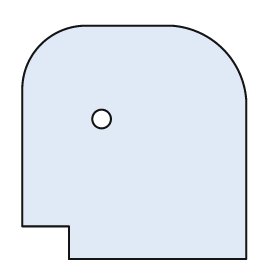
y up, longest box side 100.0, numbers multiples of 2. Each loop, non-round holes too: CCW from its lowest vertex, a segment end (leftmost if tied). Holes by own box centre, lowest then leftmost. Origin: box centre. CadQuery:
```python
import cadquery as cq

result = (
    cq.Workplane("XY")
    .moveTo(-28.0, -50.0)
    .lineTo(48.0, -50.0)
    .lineTo(48.0, 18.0)
    .threePointArc((38.0, 40.0), (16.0, 50.0))
    .lineTo(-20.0, 50.0)
    .threePointArc((-40.0, 42.0), (-48.0, 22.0))
    .lineTo(-48.0, -36.0)
    .lineTo(-28.0, -36.0)
    .close()
    .moveTo(-14.0, 10.0)
    .circle(4.0)
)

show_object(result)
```